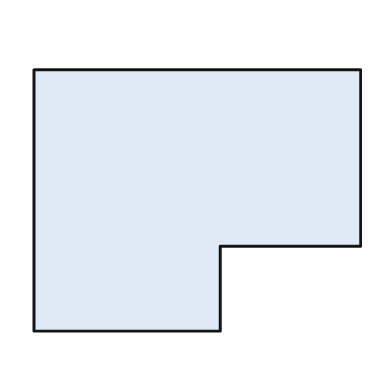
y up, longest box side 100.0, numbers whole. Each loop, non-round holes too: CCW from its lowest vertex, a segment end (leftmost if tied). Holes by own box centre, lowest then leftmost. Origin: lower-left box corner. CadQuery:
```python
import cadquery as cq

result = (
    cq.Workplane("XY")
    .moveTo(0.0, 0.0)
    .lineTo(57.0, 0.0)
    .lineTo(57.0, 26.0)
    .lineTo(100.0, 26.0)
    .lineTo(100.0, 80.0)
    .lineTo(0.0, 80.0)
    .close()
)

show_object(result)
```